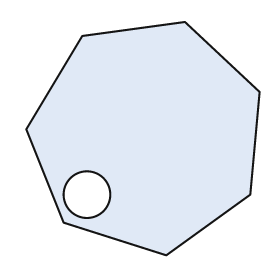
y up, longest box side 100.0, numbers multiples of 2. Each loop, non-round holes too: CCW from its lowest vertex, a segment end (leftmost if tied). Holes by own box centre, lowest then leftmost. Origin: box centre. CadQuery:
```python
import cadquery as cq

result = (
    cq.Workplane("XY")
    .moveTo(10.0, -50.0)
    .lineTo(46.0, -24.0)
    .lineTo(50.0, 20.0)
    .lineTo(18.0, 50.0)
    .lineTo(-26.0, 44.0)
    .lineTo(-50.0, 4.0)
    .lineTo(-34.0, -36.0)
    .close()
    .moveTo(-24.0, -24.0)
    .circle(10.0)
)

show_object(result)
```